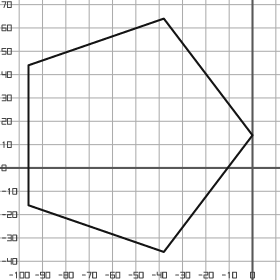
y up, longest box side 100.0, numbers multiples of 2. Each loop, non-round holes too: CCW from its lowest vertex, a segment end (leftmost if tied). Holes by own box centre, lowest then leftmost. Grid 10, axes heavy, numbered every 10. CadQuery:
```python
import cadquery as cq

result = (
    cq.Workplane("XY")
    .moveTo(-38.0, -36.0)
    .lineTo(0.0, 14.0)
    .lineTo(-38.0, 64.0)
    .lineTo(-96.0, 44.0)
    .lineTo(-96.0, -16.0)
    .close()
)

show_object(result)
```